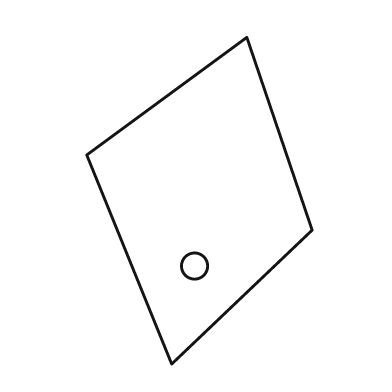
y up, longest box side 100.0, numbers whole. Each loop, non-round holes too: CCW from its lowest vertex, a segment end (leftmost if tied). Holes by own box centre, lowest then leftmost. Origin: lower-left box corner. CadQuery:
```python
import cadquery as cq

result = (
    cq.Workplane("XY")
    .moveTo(26.0, 0.0)
    .lineTo(69.0, 41.0)
    .lineTo(49.0, 100.0)
    .lineTo(0.0, 64.0)
    .close()
    .moveTo(33.0, 30.0)
    .circle(4.0)
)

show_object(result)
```